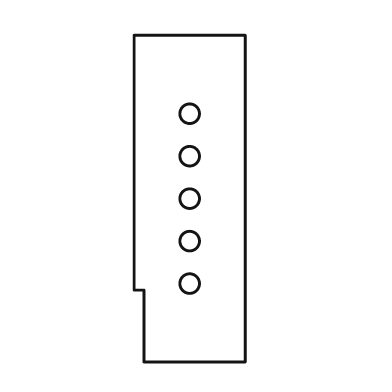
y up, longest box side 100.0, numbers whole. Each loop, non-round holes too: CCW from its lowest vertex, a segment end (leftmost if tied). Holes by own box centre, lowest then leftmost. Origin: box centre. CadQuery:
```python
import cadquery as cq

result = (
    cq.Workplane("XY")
    .moveTo(-14.0, -50.0)
    .lineTo(17.0, -50.0)
    .lineTo(17.0, 50.0)
    .lineTo(-17.0, 50.0)
    .lineTo(-17.0, -28.0)
    .lineTo(-14.0, -28.0)
    .close()
    .moveTo(0.0, -26.0)
    .circle(3.0)
    .moveTo(0.0, -13.0)
    .circle(3.0)
    .moveTo(0.0, 0.0)
    .circle(3.0)
    .moveTo(0.0, 13.0)
    .circle(3.0)
    .moveTo(0.0, 26.0)
    .circle(3.0)
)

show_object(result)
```